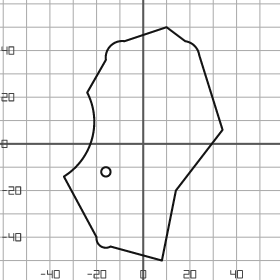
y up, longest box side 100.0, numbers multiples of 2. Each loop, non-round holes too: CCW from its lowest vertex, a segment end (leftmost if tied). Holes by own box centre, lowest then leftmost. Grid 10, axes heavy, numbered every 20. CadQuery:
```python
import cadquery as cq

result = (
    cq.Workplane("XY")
    .moveTo(8.0, -50.0)
    .lineTo(14.0, -20.0)
    .lineTo(34.0, 6.0)
    .lineTo(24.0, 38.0)
    .threePointArc((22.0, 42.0), (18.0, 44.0))
    .lineTo(10.0, 50.0)
    .lineTo(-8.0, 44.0)
    .threePointArc((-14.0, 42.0), (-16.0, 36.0))
    .lineTo(-24.0, 22.0)
    .threePointArc((-22.0, 2.0), (-34.0, -14.0))
    .lineTo(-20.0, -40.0)
    .threePointArc((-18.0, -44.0), (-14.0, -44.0))
    .close()
    .moveTo(-16.0, -12.0)
    .circle(2.0)
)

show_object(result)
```